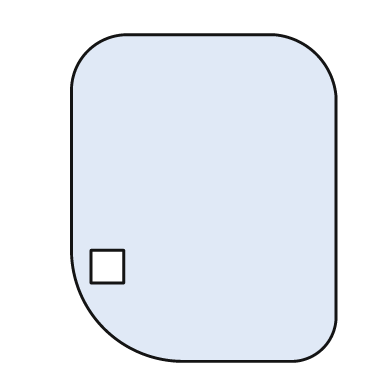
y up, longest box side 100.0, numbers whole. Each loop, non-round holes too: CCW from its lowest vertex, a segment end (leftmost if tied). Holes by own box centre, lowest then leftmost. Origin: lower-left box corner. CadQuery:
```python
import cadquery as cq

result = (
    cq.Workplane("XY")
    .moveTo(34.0, 0.0)
    .lineTo(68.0, 0.0)
    .threePointArc((77.0, 4.0), (81.0, 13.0))
    .lineTo(81.0, 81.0)
    .threePointArc((75.0, 94.0), (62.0, 100.0))
    .lineTo(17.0, 100.0)
    .threePointArc((5.0, 95.0), (0.0, 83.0))
    .lineTo(0.0, 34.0)
    .threePointArc((10.0, 10.0), (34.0, 0.0))
    .close()
    .moveTo(6.0, 24.0)
    .lineTo(16.0, 24.0)
    .lineTo(16.0, 34.0)
    .lineTo(6.0, 34.0)
    .close()
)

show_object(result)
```